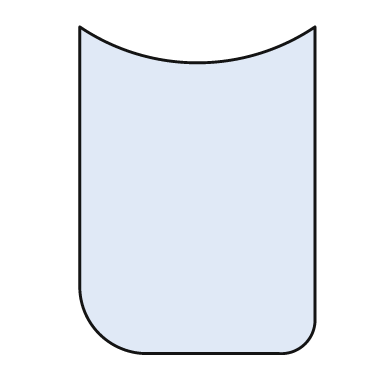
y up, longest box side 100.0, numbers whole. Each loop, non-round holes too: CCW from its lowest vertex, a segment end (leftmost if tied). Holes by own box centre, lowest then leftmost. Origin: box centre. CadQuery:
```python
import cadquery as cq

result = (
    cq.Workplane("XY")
    .moveTo(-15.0, -50.0)
    .lineTo(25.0, -50.0)
    .threePointArc((33.0, -47.0), (36.0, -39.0))
    .lineTo(36.0, 50.0)
    .threePointArc((0.0, 39.0), (-36.0, 50.0))
    .lineTo(-36.0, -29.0)
    .threePointArc((-30.0, -44.0), (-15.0, -50.0))
    .close()
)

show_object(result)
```